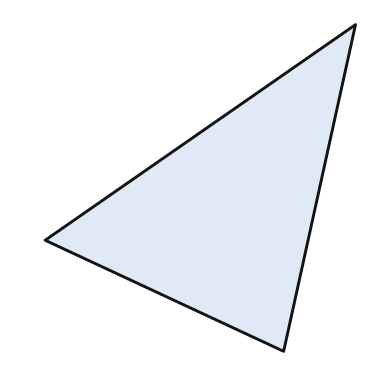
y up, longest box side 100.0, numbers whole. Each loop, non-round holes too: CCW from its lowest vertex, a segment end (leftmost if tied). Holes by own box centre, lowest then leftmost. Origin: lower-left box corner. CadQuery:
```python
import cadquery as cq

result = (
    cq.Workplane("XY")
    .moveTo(73.0, 0.0)
    .lineTo(95.0, 100.0)
    .lineTo(0.0, 34.0)
    .close()
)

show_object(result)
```